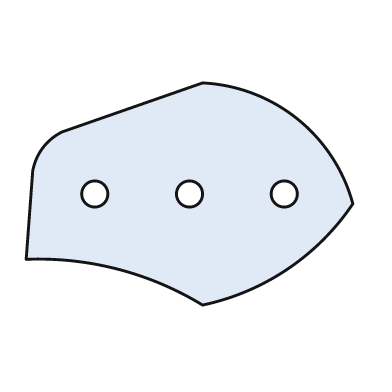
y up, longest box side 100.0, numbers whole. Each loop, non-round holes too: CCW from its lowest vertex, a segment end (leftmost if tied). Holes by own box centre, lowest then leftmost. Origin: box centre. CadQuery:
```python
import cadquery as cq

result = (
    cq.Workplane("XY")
    .moveTo(4.0, -34.0)
    .threePointArc((30.0, -23.0), (50.0, -3.0))
    .threePointArc((33.0, 23.0), (4.0, 34.0))
    .lineTo(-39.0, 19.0)
    .threePointArc((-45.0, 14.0), (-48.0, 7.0))
    .lineTo(-50.0, -20.0)
    .threePointArc((-22.0, -23.0), (4.0, -34.0))
    .close()
    .moveTo(-29.0, 0.0)
    .circle(4.0)
    .moveTo(0.0, 0.0)
    .circle(4.0)
    .moveTo(29.0, 0.0)
    .circle(4.0)
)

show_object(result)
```